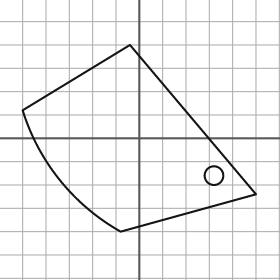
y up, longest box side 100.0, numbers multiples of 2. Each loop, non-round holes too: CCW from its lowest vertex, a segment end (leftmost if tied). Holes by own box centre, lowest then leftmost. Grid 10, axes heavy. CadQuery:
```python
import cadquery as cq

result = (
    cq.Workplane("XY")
    .moveTo(-8.0, -40.0)
    .lineTo(50.0, -24.0)
    .lineTo(-4.0, 40.0)
    .lineTo(-50.0, 12.0)
    .threePointArc((-34.0, -18.0), (-8.0, -40.0))
    .close()
    .moveTo(32.0, -16.0)
    .circle(4.0)
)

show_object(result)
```